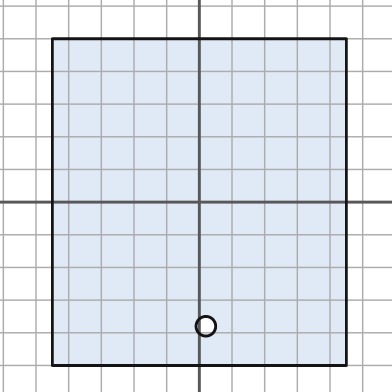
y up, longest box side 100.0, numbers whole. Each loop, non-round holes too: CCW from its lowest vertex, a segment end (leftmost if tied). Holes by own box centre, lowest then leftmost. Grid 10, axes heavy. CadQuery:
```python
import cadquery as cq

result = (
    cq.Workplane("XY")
    .moveTo(-45.0, -50.0)
    .lineTo(45.0, -50.0)
    .lineTo(45.0, 50.0)
    .lineTo(-45.0, 50.0)
    .close()
    .moveTo(2.0, -38.0)
    .circle(3.0)
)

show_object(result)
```